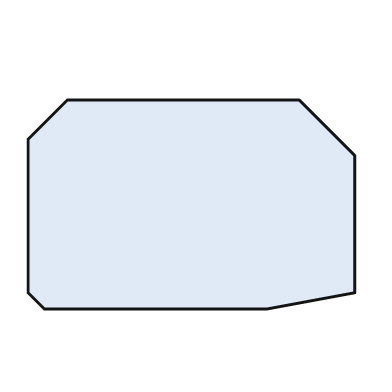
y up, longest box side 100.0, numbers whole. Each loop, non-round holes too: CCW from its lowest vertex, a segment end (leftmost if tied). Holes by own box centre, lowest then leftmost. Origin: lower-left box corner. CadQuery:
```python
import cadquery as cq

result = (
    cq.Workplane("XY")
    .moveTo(5.0, 0.0)
    .lineTo(73.0, 0.0)
    .lineTo(100.0, 5.0)
    .lineTo(100.0, 47.0)
    .lineTo(83.0, 64.0)
    .lineTo(12.0, 64.0)
    .lineTo(0.0, 52.0)
    .lineTo(0.0, 5.0)
    .close()
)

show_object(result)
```